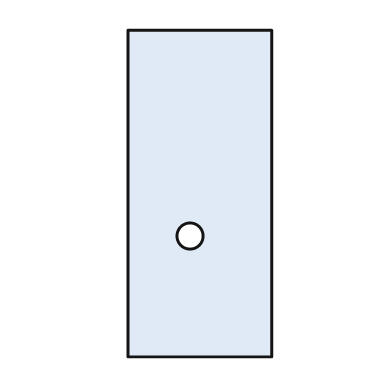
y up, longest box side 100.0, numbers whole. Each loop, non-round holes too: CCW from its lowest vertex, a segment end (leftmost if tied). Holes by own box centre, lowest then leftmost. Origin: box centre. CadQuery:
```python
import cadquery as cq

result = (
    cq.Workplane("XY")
    .moveTo(-22.0, -50.0)
    .lineTo(22.0, -50.0)
    .lineTo(22.0, 50.0)
    .lineTo(-22.0, 50.0)
    .close()
    .moveTo(-3.0, -13.0)
    .circle(4.0)
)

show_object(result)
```